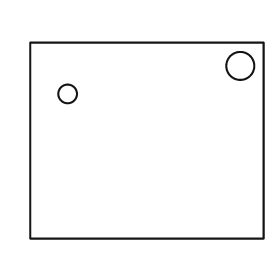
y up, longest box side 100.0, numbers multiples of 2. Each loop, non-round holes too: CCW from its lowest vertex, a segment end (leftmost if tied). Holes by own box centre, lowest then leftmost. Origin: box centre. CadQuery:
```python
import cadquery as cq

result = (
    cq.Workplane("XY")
    .moveTo(-50.0, -42.0)
    .lineTo(50.0, -42.0)
    .lineTo(50.0, 42.0)
    .lineTo(-50.0, 42.0)
    .close()
    .moveTo(-34.0, 20.0)
    .circle(4.0)
    .moveTo(40.0, 32.0)
    .circle(6.0)
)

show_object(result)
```